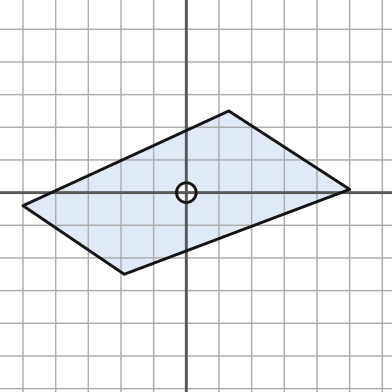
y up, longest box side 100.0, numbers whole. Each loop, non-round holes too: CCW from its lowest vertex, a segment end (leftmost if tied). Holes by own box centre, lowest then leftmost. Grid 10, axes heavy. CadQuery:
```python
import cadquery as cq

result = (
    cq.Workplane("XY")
    .moveTo(-19.0, -25.0)
    .lineTo(50.0, 1.0)
    .lineTo(13.0, 25.0)
    .lineTo(-50.0, -4.0)
    .close()
    .moveTo(0.0, 0.0)
    .circle(3.0)
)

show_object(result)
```